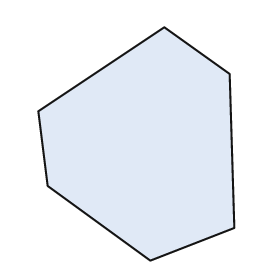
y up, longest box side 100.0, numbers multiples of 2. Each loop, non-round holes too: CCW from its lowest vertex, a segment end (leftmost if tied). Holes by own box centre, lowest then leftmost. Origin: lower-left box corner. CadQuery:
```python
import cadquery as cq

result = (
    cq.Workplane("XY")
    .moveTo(48.0, 0.0)
    .lineTo(84.0, 14.0)
    .lineTo(82.0, 80.0)
    .lineTo(54.0, 100.0)
    .lineTo(0.0, 64.0)
    .lineTo(4.0, 32.0)
    .close()
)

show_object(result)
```